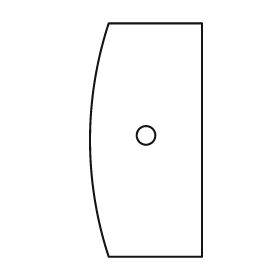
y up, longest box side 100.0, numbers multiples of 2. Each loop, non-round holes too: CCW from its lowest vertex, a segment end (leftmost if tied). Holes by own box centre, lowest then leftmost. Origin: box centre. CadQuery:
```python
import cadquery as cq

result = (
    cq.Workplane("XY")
    .moveTo(-16.0, -50.0)
    .lineTo(24.0, -50.0)
    .lineTo(24.0, 50.0)
    .lineTo(-16.0, 50.0)
    .threePointArc((-24.0, 0.0), (-16.0, -50.0))
    .close()
    .moveTo(0.0, 2.0)
    .circle(4.0)
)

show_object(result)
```